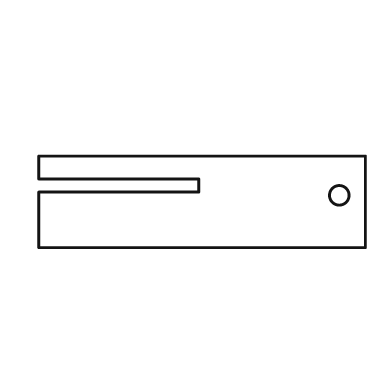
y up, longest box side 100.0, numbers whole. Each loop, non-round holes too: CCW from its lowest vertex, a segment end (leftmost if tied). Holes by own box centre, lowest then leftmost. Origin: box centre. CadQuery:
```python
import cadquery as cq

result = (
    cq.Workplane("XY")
    .moveTo(-50.0, -14.0)
    .lineTo(50.0, -14.0)
    .lineTo(50.0, 14.0)
    .lineTo(-50.0, 14.0)
    .lineTo(-50.0, 7.0)
    .lineTo(-1.0, 7.0)
    .lineTo(-1.0, 3.0)
    .lineTo(-50.0, 3.0)
    .close()
    .moveTo(42.0, 2.0)
    .circle(3.0)
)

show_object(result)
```